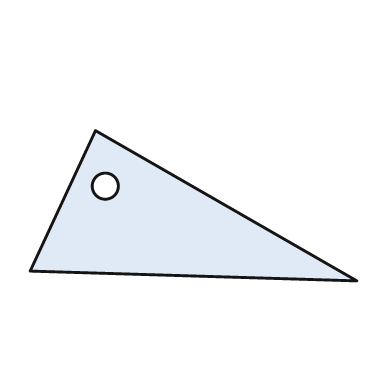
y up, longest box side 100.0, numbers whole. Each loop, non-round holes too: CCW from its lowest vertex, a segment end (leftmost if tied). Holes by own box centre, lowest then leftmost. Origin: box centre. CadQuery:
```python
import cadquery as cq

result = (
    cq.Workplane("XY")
    .moveTo(50.0, -23.0)
    .lineTo(-30.0, 23.0)
    .lineTo(-50.0, -20.0)
    .close()
    .moveTo(-27.0, 6.0)
    .circle(4.0)
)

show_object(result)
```